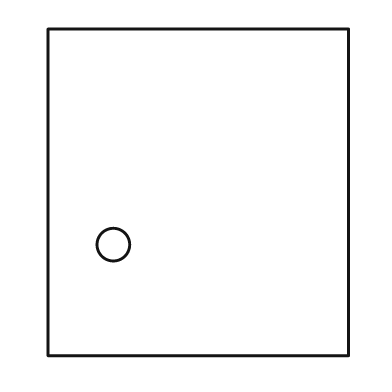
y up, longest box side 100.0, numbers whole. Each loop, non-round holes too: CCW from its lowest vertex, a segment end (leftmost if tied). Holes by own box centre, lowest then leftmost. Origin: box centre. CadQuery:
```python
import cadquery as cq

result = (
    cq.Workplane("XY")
    .moveTo(-46.0, -50.0)
    .lineTo(46.0, -50.0)
    .lineTo(46.0, 50.0)
    .lineTo(-46.0, 50.0)
    .close()
    .moveTo(-26.0, -16.0)
    .circle(5.0)
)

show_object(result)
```